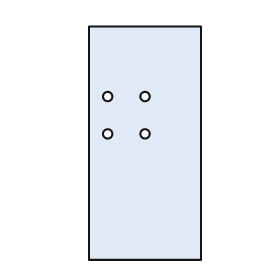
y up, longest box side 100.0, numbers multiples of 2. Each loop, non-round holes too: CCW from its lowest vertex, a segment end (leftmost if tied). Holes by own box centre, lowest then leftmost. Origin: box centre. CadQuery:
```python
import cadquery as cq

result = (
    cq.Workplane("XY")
    .moveTo(-24.0, -50.0)
    .lineTo(24.0, -50.0)
    .lineTo(24.0, 50.0)
    .lineTo(-24.0, 50.0)
    .close()
    .moveTo(-16.0, 4.0)
    .circle(2.0)
    .moveTo(0.0, 4.0)
    .circle(2.0)
    .moveTo(-16.0, 20.0)
    .circle(2.0)
    .moveTo(0.0, 20.0)
    .circle(2.0)
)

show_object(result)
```